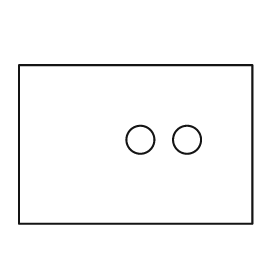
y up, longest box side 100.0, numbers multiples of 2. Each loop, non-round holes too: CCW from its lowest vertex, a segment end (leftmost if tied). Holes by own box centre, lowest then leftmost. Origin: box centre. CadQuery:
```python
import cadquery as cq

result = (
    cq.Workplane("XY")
    .moveTo(-50.0, -34.0)
    .lineTo(50.0, -34.0)
    .lineTo(50.0, 34.0)
    .lineTo(-50.0, 34.0)
    .close()
    .moveTo(2.0, 2.0)
    .circle(6.0)
    .moveTo(22.0, 2.0)
    .circle(6.0)
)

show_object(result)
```